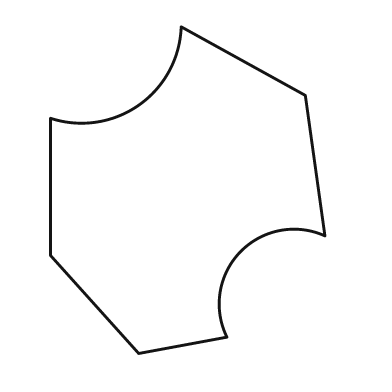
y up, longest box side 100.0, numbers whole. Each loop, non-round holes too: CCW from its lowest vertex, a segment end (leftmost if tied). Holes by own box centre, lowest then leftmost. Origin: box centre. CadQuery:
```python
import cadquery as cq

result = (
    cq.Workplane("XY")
    .moveTo(-15.0, -50.0)
    .lineTo(12.0, -45.0)
    .threePointArc((16.0, -19.0), (42.0, -14.0))
    .lineTo(36.0, 29.0)
    .lineTo(-2.0, 50.0)
    .threePointArc((-15.0, 26.0), (-42.0, 22.0))
    .lineTo(-42.0, -20.0)
    .close()
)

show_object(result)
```